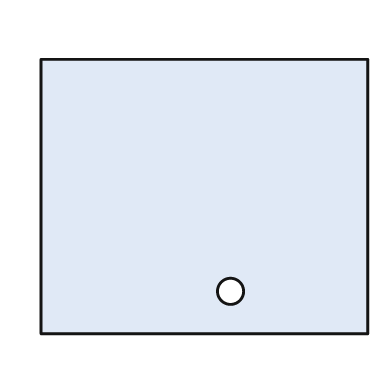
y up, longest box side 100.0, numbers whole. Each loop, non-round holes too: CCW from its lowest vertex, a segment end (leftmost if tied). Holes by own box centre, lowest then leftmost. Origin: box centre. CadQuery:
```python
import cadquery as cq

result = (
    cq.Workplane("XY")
    .moveTo(-50.0, -42.0)
    .lineTo(50.0, -42.0)
    .lineTo(50.0, 42.0)
    .lineTo(-50.0, 42.0)
    .close()
    .moveTo(8.0, -29.0)
    .circle(4.0)
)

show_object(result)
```